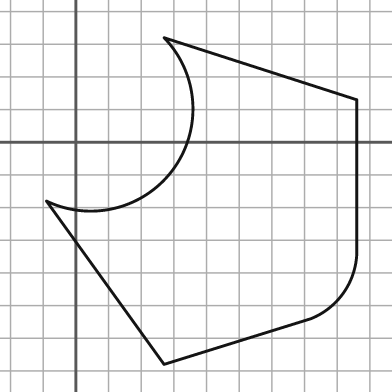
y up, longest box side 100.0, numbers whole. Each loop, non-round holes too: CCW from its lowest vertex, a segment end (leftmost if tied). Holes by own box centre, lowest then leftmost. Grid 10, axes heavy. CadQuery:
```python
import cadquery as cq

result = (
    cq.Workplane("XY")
    .moveTo(27.0, -68.0)
    .lineTo(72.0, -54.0)
    .threePointArc((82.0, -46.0), (86.0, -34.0))
    .lineTo(86.0, 13.0)
    .lineTo(27.0, 32.0)
    .threePointArc((30.0, -8.0), (-9.0, -18.0))
    .close()
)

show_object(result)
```